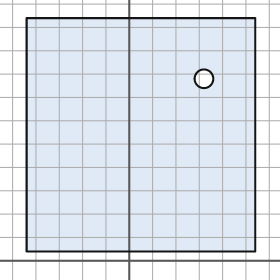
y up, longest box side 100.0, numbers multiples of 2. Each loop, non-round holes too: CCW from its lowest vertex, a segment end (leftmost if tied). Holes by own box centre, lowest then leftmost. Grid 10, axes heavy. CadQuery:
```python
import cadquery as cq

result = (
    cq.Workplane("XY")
    .moveTo(-44.0, 4.0)
    .lineTo(54.0, 4.0)
    .lineTo(54.0, 104.0)
    .lineTo(-44.0, 104.0)
    .close()
    .moveTo(32.0, 78.0)
    .circle(4.0)
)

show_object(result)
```